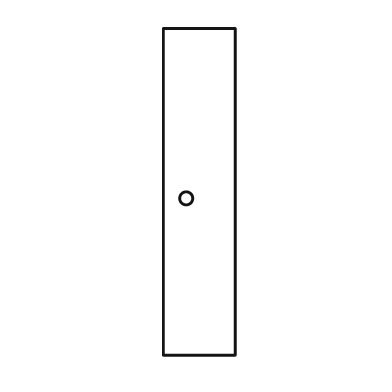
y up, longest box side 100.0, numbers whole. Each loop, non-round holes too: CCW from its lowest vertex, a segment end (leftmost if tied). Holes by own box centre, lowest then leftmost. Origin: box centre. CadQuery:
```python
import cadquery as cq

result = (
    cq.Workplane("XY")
    .moveTo(-11.0, -50.0)
    .lineTo(11.0, -50.0)
    .lineTo(11.0, 50.0)
    .lineTo(-11.0, 50.0)
    .close()
    .moveTo(-4.0, -2.0)
    .circle(2.0)
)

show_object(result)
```